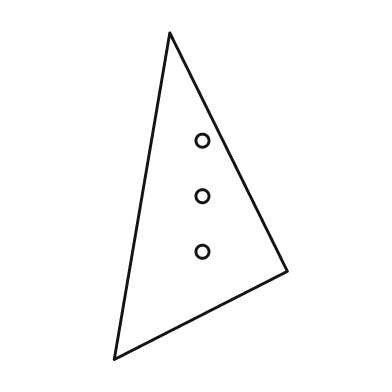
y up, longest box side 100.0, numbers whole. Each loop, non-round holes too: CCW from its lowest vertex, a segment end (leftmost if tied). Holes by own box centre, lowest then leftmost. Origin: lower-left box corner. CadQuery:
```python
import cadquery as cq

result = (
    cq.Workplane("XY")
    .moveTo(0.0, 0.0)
    .lineTo(53.0, 27.0)
    .lineTo(17.0, 100.0)
    .close()
    .moveTo(27.0, 33.0)
    .circle(2.0)
    .moveTo(27.0, 50.0)
    .circle(2.0)
    .moveTo(27.0, 67.0)
    .circle(2.0)
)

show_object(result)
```